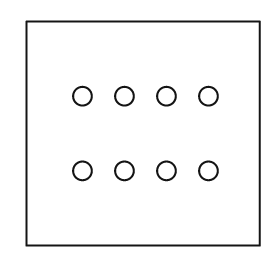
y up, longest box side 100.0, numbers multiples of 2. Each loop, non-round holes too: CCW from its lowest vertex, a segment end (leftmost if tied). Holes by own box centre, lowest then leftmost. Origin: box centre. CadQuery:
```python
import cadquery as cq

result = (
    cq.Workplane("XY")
    .moveTo(-50.0, -48.0)
    .lineTo(50.0, -48.0)
    .lineTo(50.0, 48.0)
    .lineTo(-50.0, 48.0)
    .close()
    .moveTo(-26.0, -16.0)
    .circle(4.0)
    .moveTo(-8.0, -16.0)
    .circle(4.0)
    .moveTo(10.0, -16.0)
    .circle(4.0)
    .moveTo(28.0, -16.0)
    .circle(4.0)
    .moveTo(-26.0, 16.0)
    .circle(4.0)
    .moveTo(-8.0, 16.0)
    .circle(4.0)
    .moveTo(10.0, 16.0)
    .circle(4.0)
    .moveTo(28.0, 16.0)
    .circle(4.0)
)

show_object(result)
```